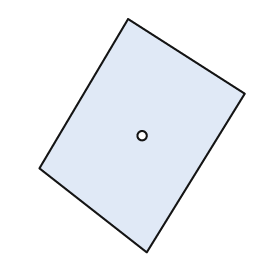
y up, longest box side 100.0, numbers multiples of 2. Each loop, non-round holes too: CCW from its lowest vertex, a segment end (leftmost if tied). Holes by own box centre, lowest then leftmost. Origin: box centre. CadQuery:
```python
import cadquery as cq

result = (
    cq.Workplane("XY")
    .moveTo(2.0, -50.0)
    .lineTo(44.0, 18.0)
    .lineTo(-6.0, 50.0)
    .lineTo(-44.0, -14.0)
    .close()
    .moveTo(0.0, 0.0)
    .circle(2.0)
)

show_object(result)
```